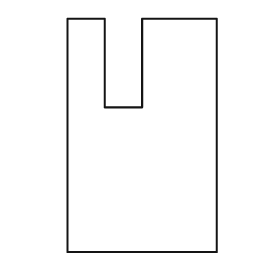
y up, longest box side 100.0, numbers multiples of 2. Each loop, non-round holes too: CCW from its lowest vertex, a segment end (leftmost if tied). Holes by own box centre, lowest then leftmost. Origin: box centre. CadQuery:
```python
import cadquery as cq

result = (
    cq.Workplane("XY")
    .moveTo(-32.0, -50.0)
    .lineTo(32.0, -50.0)
    .lineTo(32.0, 50.0)
    .lineTo(0.0, 50.0)
    .lineTo(0.0, 12.0)
    .lineTo(-16.0, 12.0)
    .lineTo(-16.0, 50.0)
    .lineTo(-32.0, 50.0)
    .close()
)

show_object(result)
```